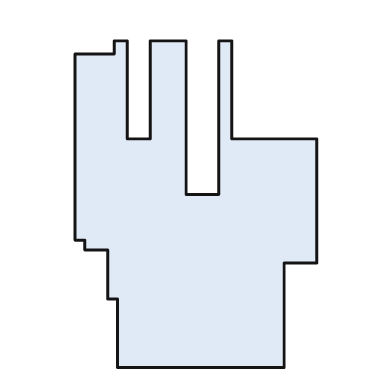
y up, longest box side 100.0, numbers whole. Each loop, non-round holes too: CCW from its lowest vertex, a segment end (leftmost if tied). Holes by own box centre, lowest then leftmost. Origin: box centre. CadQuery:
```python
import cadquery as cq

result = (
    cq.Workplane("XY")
    .moveTo(-24.0, -50.0)
    .lineTo(27.0, -50.0)
    .lineTo(27.0, -18.0)
    .lineTo(37.0, -18.0)
    .lineTo(37.0, 20.0)
    .lineTo(11.0, 20.0)
    .lineTo(11.0, 50.0)
    .lineTo(7.0, 50.0)
    .lineTo(7.0, 3.0)
    .lineTo(-3.0, 3.0)
    .lineTo(-3.0, 50.0)
    .lineTo(-14.0, 50.0)
    .lineTo(-14.0, 20.0)
    .lineTo(-21.0, 20.0)
    .lineTo(-21.0, 50.0)
    .lineTo(-25.0, 50.0)
    .lineTo(-25.0, 46.0)
    .lineTo(-37.0, 46.0)
    .lineTo(-37.0, -11.0)
    .lineTo(-34.0, -11.0)
    .lineTo(-34.0, -14.0)
    .lineTo(-27.0, -14.0)
    .lineTo(-27.0, -29.0)
    .lineTo(-24.0, -29.0)
    .close()
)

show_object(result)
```